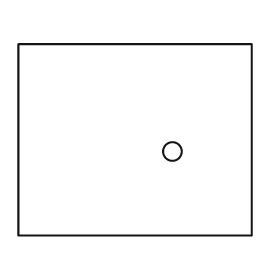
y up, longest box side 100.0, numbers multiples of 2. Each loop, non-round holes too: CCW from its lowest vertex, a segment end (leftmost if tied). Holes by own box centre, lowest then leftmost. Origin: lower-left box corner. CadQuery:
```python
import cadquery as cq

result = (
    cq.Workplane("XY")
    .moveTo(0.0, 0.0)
    .lineTo(100.0, 0.0)
    .lineTo(100.0, 82.0)
    .lineTo(0.0, 82.0)
    .close()
    .moveTo(66.0, 36.0)
    .circle(4.0)
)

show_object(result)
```